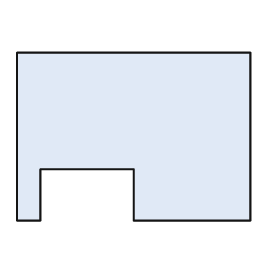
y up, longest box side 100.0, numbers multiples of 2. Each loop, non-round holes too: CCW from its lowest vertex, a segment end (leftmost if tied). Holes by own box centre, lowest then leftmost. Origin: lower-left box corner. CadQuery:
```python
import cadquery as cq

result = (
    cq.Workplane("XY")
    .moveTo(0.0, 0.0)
    .lineTo(10.0, 0.0)
    .lineTo(10.0, 22.0)
    .lineTo(50.0, 22.0)
    .lineTo(50.0, 0.0)
    .lineTo(100.0, 0.0)
    .lineTo(100.0, 72.0)
    .lineTo(0.0, 72.0)
    .close()
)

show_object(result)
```